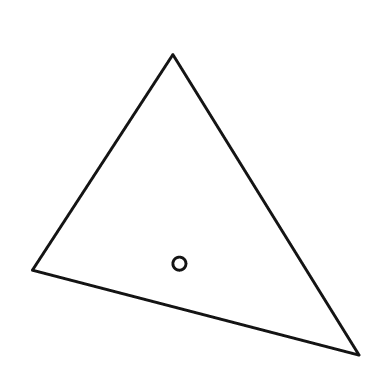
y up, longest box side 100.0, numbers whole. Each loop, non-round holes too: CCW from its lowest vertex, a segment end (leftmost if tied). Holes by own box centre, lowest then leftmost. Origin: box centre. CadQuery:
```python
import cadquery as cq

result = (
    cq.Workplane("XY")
    .moveTo(50.0, -46.0)
    .lineTo(-7.0, 46.0)
    .lineTo(-50.0, -20.0)
    .close()
    .moveTo(-5.0, -18.0)
    .circle(2.0)
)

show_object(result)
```